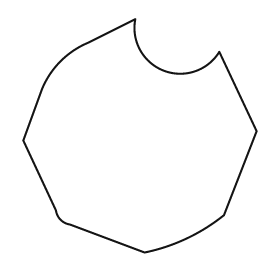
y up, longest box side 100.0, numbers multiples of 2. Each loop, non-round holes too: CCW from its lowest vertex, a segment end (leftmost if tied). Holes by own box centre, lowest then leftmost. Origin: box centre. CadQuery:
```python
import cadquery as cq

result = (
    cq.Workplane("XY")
    .moveTo(2.0, -50.0)
    .threePointArc((20.0, -44.0), (36.0, -34.0))
    .lineTo(50.0, 2.0)
    .lineTo(34.0, 36.0)
    .threePointArc((10.0, 28.0), (-2.0, 50.0))
    .lineTo(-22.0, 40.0)
    .threePointArc((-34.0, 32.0), (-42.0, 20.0))
    .lineTo(-50.0, -2.0)
    .lineTo(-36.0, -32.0)
    .threePointArc((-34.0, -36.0), (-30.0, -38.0))
    .close()
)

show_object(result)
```